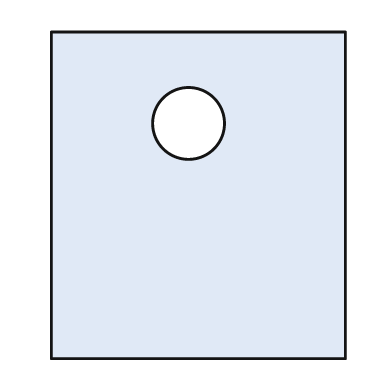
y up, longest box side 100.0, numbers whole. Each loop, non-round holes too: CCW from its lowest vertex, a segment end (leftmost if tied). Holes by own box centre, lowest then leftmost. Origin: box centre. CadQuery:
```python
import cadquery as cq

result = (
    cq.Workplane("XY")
    .moveTo(-45.0, -50.0)
    .lineTo(45.0, -50.0)
    .lineTo(45.0, 50.0)
    .lineTo(-45.0, 50.0)
    .close()
    .moveTo(-3.0, 22.0)
    .circle(11.0)
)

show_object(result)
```